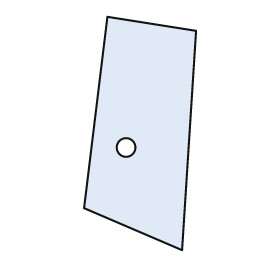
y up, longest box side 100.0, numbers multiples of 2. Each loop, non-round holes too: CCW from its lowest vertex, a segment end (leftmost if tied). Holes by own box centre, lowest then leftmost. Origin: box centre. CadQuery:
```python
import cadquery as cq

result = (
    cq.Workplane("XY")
    .moveTo(18.0, -50.0)
    .lineTo(24.0, 44.0)
    .lineTo(-14.0, 50.0)
    .lineTo(-24.0, -32.0)
    .close()
    .moveTo(-6.0, -6.0)
    .circle(4.0)
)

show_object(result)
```